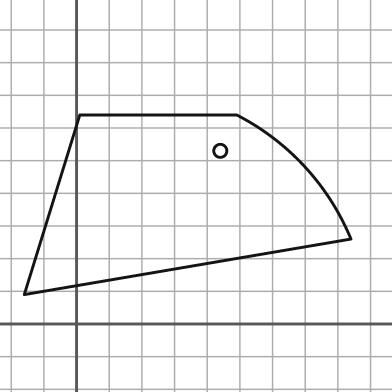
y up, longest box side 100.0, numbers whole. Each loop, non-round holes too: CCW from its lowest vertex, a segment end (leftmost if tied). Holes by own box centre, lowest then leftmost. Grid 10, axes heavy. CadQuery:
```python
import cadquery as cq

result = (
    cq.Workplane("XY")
    .moveTo(-16.0, 9.0)
    .lineTo(84.0, 26.0)
    .threePointArc((70.0, 48.0), (49.0, 64.0))
    .lineTo(1.0, 64.0)
    .close()
    .moveTo(44.0, 53.0)
    .circle(2.0)
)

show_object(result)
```